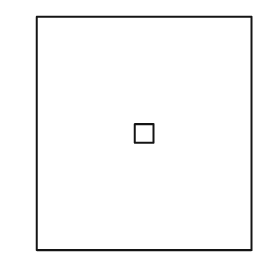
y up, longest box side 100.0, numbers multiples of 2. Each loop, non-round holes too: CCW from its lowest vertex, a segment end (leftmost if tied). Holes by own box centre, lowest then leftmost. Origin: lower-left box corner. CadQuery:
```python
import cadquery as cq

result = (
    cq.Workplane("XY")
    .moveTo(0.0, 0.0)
    .lineTo(92.0, 0.0)
    .lineTo(92.0, 100.0)
    .lineTo(0.0, 100.0)
    .close()
    .moveTo(42.0, 46.0)
    .lineTo(50.0, 46.0)
    .lineTo(50.0, 54.0)
    .lineTo(42.0, 54.0)
    .close()
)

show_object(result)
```